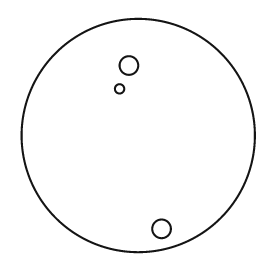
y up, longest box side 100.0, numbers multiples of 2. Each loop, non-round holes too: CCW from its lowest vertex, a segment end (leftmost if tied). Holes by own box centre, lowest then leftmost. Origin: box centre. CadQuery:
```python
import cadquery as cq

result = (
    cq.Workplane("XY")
    .moveTo(0.0, 0.0)
    .circle(50.0)
    .moveTo(10.0, -40.0)
    .circle(4.0)
    .moveTo(-8.0, 20.0)
    .circle(2.0)
    .moveTo(-4.0, 30.0)
    .circle(4.0)
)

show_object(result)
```